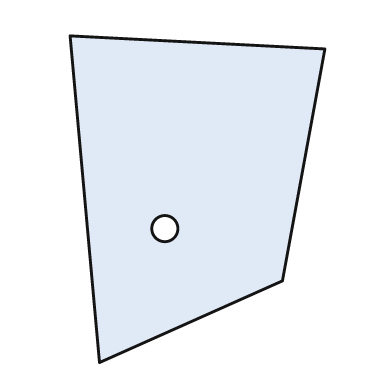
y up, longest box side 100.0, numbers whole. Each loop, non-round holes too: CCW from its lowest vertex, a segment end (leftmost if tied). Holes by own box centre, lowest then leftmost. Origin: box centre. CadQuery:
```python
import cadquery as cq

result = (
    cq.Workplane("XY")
    .moveTo(-30.0, -50.0)
    .lineTo(26.0, -25.0)
    .lineTo(39.0, 46.0)
    .lineTo(-39.0, 50.0)
    .close()
    .moveTo(-10.0, -9.0)
    .circle(4.0)
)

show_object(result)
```